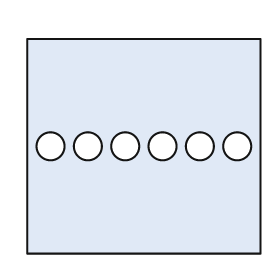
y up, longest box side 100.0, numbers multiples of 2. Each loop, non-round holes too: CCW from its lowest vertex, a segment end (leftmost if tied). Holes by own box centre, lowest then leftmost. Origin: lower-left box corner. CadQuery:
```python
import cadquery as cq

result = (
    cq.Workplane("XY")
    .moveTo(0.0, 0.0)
    .lineTo(100.0, 0.0)
    .lineTo(100.0, 92.0)
    .lineTo(0.0, 92.0)
    .close()
    .moveTo(10.0, 46.0)
    .circle(6.0)
    .moveTo(26.0, 46.0)
    .circle(6.0)
    .moveTo(42.0, 46.0)
    .circle(6.0)
    .moveTo(58.0, 46.0)
    .circle(6.0)
    .moveTo(74.0, 46.0)
    .circle(6.0)
    .moveTo(90.0, 46.0)
    .circle(6.0)
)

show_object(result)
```